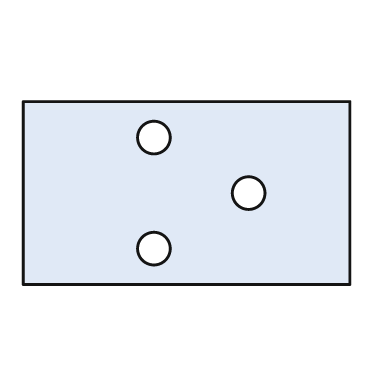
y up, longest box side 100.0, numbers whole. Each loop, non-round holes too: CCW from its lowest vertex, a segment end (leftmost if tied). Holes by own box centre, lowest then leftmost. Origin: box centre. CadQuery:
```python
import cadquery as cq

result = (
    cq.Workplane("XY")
    .moveTo(-50.0, -28.0)
    .lineTo(50.0, -28.0)
    .lineTo(50.0, 28.0)
    .lineTo(-50.0, 28.0)
    .close()
    .moveTo(-10.0, -17.0)
    .circle(5.0)
    .moveTo(19.0, 0.0)
    .circle(5.0)
    .moveTo(-10.0, 17.0)
    .circle(5.0)
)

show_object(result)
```